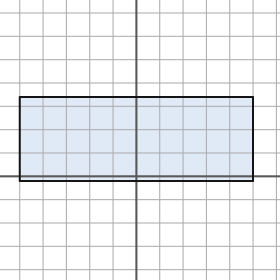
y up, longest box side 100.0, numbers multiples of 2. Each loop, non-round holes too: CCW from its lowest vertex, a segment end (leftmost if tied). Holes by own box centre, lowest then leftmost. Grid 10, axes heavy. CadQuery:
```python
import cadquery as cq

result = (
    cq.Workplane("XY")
    .moveTo(-50.0, -2.0)
    .lineTo(50.0, -2.0)
    .lineTo(50.0, 34.0)
    .lineTo(-50.0, 34.0)
    .close()
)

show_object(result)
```